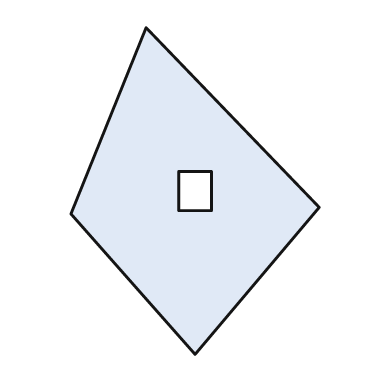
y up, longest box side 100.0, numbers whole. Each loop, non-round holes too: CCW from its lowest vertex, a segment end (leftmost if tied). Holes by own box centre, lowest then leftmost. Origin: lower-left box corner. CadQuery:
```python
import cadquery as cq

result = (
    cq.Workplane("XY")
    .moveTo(38.0, 0.0)
    .lineTo(76.0, 45.0)
    .lineTo(23.0, 100.0)
    .lineTo(0.0, 43.0)
    .close()
    .moveTo(33.0, 44.0)
    .lineTo(43.0, 44.0)
    .lineTo(43.0, 56.0)
    .lineTo(33.0, 56.0)
    .close()
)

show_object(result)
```